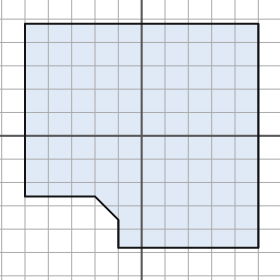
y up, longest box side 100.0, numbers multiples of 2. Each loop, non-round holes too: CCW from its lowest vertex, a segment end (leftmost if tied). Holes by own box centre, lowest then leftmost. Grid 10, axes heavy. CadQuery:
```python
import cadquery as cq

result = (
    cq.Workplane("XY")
    .moveTo(-10.0, -48.0)
    .lineTo(50.0, -48.0)
    .lineTo(50.0, 48.0)
    .lineTo(-50.0, 48.0)
    .lineTo(-50.0, -26.0)
    .lineTo(-20.0, -26.0)
    .lineTo(-10.0, -36.0)
    .close()
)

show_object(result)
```